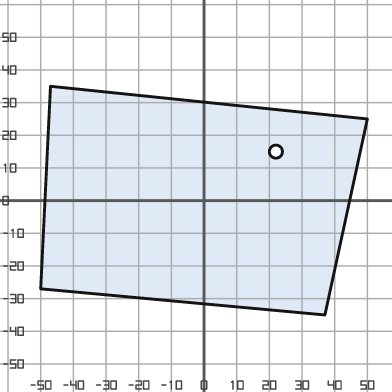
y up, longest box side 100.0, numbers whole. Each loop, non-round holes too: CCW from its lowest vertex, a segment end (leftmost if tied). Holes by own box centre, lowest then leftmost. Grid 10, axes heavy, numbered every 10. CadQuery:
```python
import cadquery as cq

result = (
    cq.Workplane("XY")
    .moveTo(37.0, -35.0)
    .lineTo(50.0, 25.0)
    .lineTo(-47.0, 35.0)
    .lineTo(-50.0, -27.0)
    .close()
    .moveTo(22.0, 15.0)
    .circle(2.0)
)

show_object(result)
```